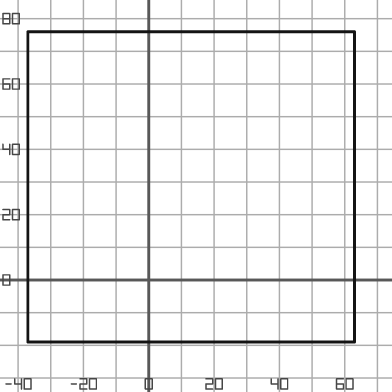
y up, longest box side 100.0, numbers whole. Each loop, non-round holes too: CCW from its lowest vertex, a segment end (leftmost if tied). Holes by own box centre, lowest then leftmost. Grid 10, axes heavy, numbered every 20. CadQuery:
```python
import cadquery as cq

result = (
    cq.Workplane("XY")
    .moveTo(-37.0, -19.0)
    .lineTo(63.0, -19.0)
    .lineTo(63.0, 76.0)
    .lineTo(-37.0, 76.0)
    .close()
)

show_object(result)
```